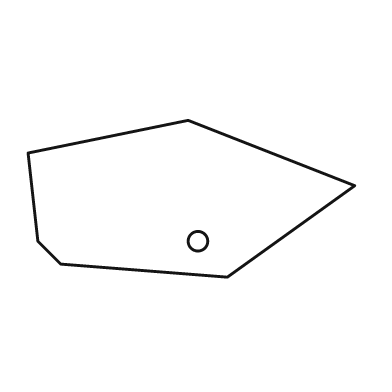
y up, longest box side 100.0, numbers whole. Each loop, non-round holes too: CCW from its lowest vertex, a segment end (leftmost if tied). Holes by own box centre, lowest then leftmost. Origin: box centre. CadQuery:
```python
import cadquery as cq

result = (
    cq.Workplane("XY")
    .moveTo(11.0, -24.0)
    .lineTo(50.0, 4.0)
    .lineTo(-1.0, 24.0)
    .lineTo(-50.0, 14.0)
    .lineTo(-47.0, -13.0)
    .lineTo(-40.0, -20.0)
    .close()
    .moveTo(2.0, -13.0)
    .circle(3.0)
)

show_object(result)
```